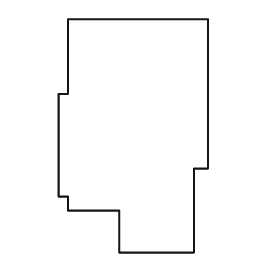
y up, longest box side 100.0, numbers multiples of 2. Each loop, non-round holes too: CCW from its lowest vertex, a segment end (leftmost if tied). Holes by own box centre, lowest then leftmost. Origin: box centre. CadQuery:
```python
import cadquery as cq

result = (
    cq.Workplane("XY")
    .moveTo(-6.0, -50.0)
    .lineTo(26.0, -50.0)
    .lineTo(26.0, -14.0)
    .lineTo(32.0, -14.0)
    .lineTo(32.0, 50.0)
    .lineTo(-28.0, 50.0)
    .lineTo(-28.0, 18.0)
    .lineTo(-32.0, 18.0)
    .lineTo(-32.0, -26.0)
    .lineTo(-28.0, -26.0)
    .lineTo(-28.0, -32.0)
    .lineTo(-6.0, -32.0)
    .close()
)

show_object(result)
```